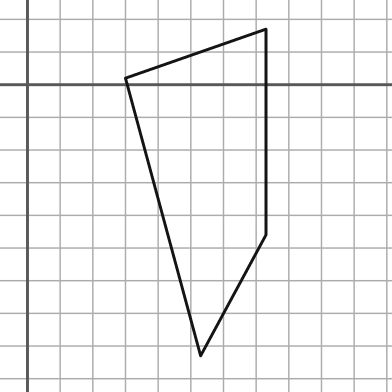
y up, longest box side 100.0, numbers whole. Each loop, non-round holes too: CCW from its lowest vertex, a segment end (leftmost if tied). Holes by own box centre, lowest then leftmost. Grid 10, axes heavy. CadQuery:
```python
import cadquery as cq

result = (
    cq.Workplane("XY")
    .moveTo(53.0, -83.0)
    .lineTo(73.0, -46.0)
    .lineTo(73.0, 17.0)
    .lineTo(30.0, 2.0)
    .close()
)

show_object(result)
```